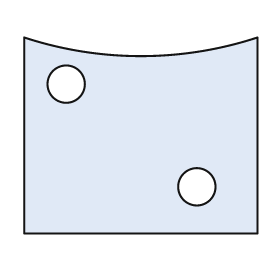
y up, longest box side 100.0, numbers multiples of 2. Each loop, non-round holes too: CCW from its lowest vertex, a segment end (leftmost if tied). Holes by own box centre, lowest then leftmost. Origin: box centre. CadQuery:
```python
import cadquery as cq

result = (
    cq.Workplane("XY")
    .moveTo(-50.0, -42.0)
    .lineTo(50.0, -42.0)
    .lineTo(50.0, 42.0)
    .threePointArc((0.0, 34.0), (-50.0, 42.0))
    .close()
    .moveTo(24.0, -22.0)
    .circle(8.0)
    .moveTo(-32.0, 22.0)
    .circle(8.0)
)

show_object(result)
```